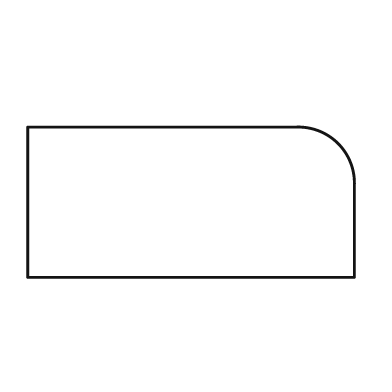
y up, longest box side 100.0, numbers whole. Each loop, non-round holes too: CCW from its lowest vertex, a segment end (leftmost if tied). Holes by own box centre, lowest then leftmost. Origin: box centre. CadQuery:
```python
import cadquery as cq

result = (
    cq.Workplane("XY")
    .moveTo(-50.0, -23.0)
    .lineTo(50.0, -23.0)
    .lineTo(50.0, 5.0)
    .threePointArc((45.0, 18.0), (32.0, 23.0))
    .lineTo(-50.0, 23.0)
    .close()
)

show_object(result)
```